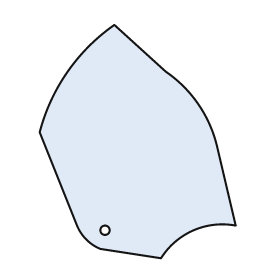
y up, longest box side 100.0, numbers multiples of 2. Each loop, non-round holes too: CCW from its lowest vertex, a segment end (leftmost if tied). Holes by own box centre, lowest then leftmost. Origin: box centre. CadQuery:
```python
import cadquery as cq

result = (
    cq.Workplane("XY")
    .moveTo(10.0, -50.0)
    .threePointArc((24.0, -38.0), (42.0, -36.0))
    .lineTo(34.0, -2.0)
    .threePointArc((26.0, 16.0), (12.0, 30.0))
    .lineTo(-10.0, 50.0)
    .threePointArc((-30.0, 30.0), (-42.0, 4.0))
    .lineTo(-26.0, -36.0)
    .threePointArc((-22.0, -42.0), (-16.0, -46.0))
    .close()
    .moveTo(-14.0, -38.0)
    .circle(2.0)
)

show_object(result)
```